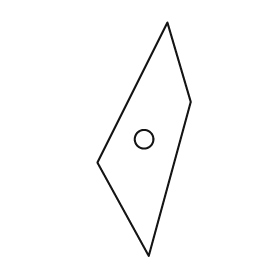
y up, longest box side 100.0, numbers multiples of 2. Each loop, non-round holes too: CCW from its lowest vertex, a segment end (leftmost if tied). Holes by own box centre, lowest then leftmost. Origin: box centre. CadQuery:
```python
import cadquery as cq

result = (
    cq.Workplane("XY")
    .moveTo(2.0, -50.0)
    .lineTo(20.0, 16.0)
    .lineTo(10.0, 50.0)
    .lineTo(-20.0, -10.0)
    .close()
    .moveTo(0.0, 0.0)
    .circle(4.0)
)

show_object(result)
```